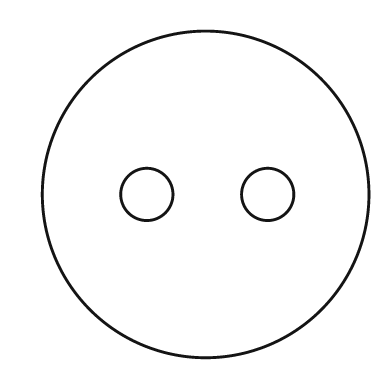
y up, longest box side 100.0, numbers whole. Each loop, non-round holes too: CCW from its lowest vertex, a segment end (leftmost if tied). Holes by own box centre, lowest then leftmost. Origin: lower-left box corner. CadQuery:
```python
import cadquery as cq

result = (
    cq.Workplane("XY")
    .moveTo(50.0, 50.0)
    .circle(50.0)
    .moveTo(32.0, 50.0)
    .circle(8.0)
    .moveTo(69.0, 50.0)
    .circle(8.0)
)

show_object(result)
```